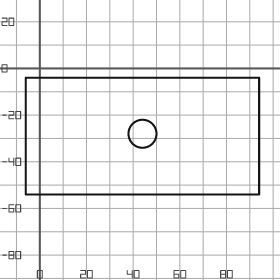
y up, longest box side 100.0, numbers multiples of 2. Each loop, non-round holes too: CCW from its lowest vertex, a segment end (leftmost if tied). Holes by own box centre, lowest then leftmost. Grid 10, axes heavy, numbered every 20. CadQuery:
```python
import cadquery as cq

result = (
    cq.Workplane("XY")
    .moveTo(-6.0, -54.0)
    .lineTo(94.0, -54.0)
    .lineTo(94.0, -4.0)
    .lineTo(-6.0, -4.0)
    .close()
    .moveTo(44.0, -28.0)
    .circle(6.0)
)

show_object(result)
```